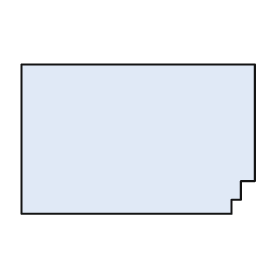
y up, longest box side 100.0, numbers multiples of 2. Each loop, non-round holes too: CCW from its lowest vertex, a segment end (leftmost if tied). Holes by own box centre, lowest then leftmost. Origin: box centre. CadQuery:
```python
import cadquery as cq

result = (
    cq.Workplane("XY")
    .moveTo(-50.0, -32.0)
    .lineTo(40.0, -32.0)
    .lineTo(40.0, -26.0)
    .lineTo(44.0, -26.0)
    .lineTo(44.0, -18.0)
    .lineTo(50.0, -18.0)
    .lineTo(50.0, 32.0)
    .lineTo(-50.0, 32.0)
    .close()
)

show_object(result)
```